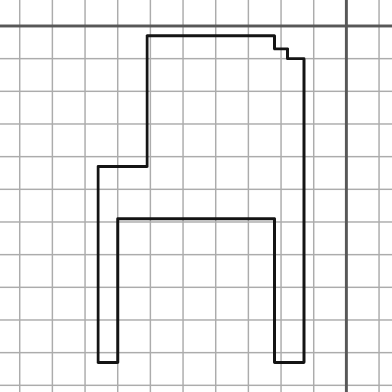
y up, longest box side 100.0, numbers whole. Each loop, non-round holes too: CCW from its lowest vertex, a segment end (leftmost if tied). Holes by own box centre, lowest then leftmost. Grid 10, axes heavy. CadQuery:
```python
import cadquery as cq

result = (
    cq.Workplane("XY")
    .moveTo(-76.0, -103.0)
    .lineTo(-70.0, -103.0)
    .lineTo(-70.0, -59.0)
    .lineTo(-22.0, -59.0)
    .lineTo(-22.0, -103.0)
    .lineTo(-13.0, -103.0)
    .lineTo(-13.0, -10.0)
    .lineTo(-18.0, -10.0)
    .lineTo(-18.0, -7.0)
    .lineTo(-22.0, -7.0)
    .lineTo(-22.0, -3.0)
    .lineTo(-61.0, -3.0)
    .lineTo(-61.0, -43.0)
    .lineTo(-76.0, -43.0)
    .close()
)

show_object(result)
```